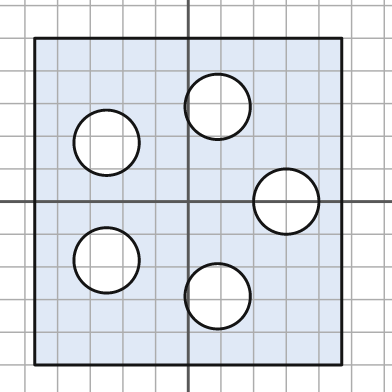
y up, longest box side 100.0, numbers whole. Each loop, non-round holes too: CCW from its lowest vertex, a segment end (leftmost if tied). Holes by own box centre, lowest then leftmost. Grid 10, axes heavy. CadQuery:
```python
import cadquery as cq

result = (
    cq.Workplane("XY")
    .moveTo(-47.0, -50.0)
    .lineTo(47.0, -50.0)
    .lineTo(47.0, 50.0)
    .lineTo(-47.0, 50.0)
    .close()
    .moveTo(9.0, -29.0)
    .circle(10.0)
    .moveTo(-25.0, -18.0)
    .circle(10.0)
    .moveTo(30.0, 0.0)
    .circle(10.0)
    .moveTo(-25.0, 18.0)
    .circle(10.0)
    .moveTo(9.0, 29.0)
    .circle(10.0)
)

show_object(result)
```